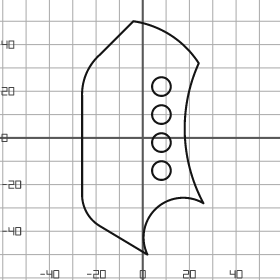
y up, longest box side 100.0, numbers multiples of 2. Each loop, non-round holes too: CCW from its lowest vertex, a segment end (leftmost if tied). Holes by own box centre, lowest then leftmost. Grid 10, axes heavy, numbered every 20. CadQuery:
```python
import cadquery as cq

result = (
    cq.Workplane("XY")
    .moveTo(2.0, -50.0)
    .threePointArc((6.0, -30.0), (26.0, -28.0))
    .threePointArc((18.0, 2.0), (24.0, 32.0))
    .threePointArc((12.0, 44.0), (-4.0, 50.0))
    .lineTo(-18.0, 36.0)
    .threePointArc((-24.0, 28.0), (-26.0, 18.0))
    .lineTo(-26.0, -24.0)
    .threePointArc((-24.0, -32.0), (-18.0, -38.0))
    .close()
    .moveTo(8.0, -14.0)
    .circle(4.0)
    .moveTo(8.0, -2.0)
    .circle(4.0)
    .moveTo(8.0, 10.0)
    .circle(4.0)
    .moveTo(8.0, 22.0)
    .circle(4.0)
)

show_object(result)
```